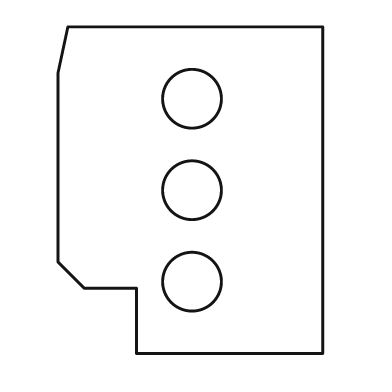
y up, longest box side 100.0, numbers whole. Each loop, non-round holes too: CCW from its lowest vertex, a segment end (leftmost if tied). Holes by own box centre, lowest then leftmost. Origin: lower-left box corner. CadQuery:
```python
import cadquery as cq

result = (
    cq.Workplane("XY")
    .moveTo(24.0, 0.0)
    .lineTo(81.0, 0.0)
    .lineTo(81.0, 100.0)
    .lineTo(3.0, 100.0)
    .lineTo(0.0, 86.0)
    .lineTo(0.0, 28.0)
    .lineTo(8.0, 20.0)
    .lineTo(24.0, 20.0)
    .close()
    .moveTo(41.0, 22.0)
    .circle(9.0)
    .moveTo(41.0, 50.0)
    .circle(9.0)
    .moveTo(41.0, 78.0)
    .circle(9.0)
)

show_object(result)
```